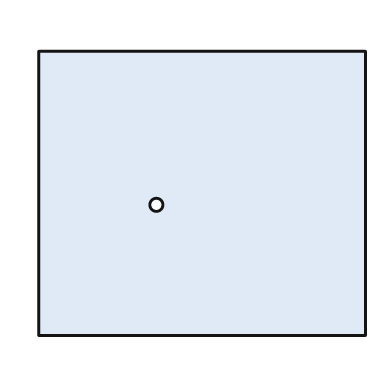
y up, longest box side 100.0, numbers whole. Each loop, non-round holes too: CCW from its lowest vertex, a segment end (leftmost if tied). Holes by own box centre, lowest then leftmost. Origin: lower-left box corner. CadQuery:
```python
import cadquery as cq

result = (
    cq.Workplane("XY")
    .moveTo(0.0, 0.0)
    .lineTo(100.0, 0.0)
    .lineTo(100.0, 87.0)
    .lineTo(0.0, 87.0)
    .close()
    .moveTo(36.0, 40.0)
    .circle(2.0)
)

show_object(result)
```